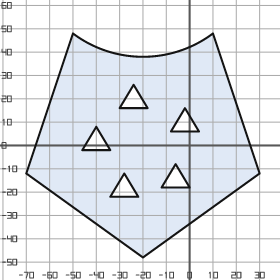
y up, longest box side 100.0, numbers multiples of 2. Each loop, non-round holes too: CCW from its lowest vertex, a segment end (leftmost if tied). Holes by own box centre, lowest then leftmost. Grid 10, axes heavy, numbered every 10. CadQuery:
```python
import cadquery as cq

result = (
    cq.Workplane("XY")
    .moveTo(-20.0, -48.0)
    .lineTo(30.0, -12.0)
    .lineTo(10.0, 48.0)
    .threePointArc((-20.0, 38.0), (-50.0, 48.0))
    .lineTo(-70.0, -12.0)
    .close()
    .moveTo(-34.0, -22.0)
    .lineTo(-22.0, -22.0)
    .lineTo(-28.0, -12.0)
    .close()
    .moveTo(-12.0, -18.0)
    .lineTo(0.0, -18.0)
    .lineTo(-6.0, -8.0)
    .close()
    .moveTo(-46.0, -2.0)
    .lineTo(-34.0, -2.0)
    .lineTo(-40.0, 8.0)
    .close()
    .moveTo(-8.0, 6.0)
    .lineTo(4.0, 6.0)
    .lineTo(-2.0, 16.0)
    .close()
    .moveTo(-30.0, 16.0)
    .lineTo(-18.0, 16.0)
    .lineTo(-24.0, 26.0)
    .close()
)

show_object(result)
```